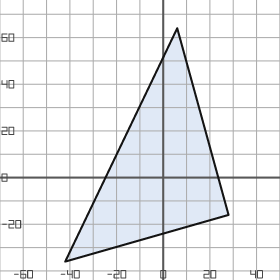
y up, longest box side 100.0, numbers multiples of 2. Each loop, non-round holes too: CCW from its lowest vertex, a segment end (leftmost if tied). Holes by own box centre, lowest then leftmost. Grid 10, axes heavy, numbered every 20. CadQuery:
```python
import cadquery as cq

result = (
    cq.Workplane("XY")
    .moveTo(-42.0, -36.0)
    .lineTo(28.0, -16.0)
    .lineTo(6.0, 64.0)
    .close()
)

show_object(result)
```